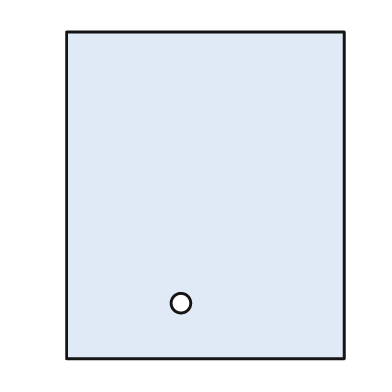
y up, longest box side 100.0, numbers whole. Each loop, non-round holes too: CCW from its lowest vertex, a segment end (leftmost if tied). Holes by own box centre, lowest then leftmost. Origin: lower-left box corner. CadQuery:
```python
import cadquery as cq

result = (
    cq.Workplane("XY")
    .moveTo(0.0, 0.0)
    .lineTo(85.0, 0.0)
    .lineTo(85.0, 100.0)
    .lineTo(0.0, 100.0)
    .close()
    .moveTo(35.0, 17.0)
    .circle(3.0)
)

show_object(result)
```